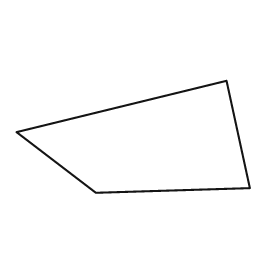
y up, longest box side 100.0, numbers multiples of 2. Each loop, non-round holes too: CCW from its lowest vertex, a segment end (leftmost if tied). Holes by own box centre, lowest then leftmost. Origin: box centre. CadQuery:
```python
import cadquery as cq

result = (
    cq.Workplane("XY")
    .moveTo(-16.0, -24.0)
    .lineTo(50.0, -22.0)
    .lineTo(40.0, 24.0)
    .lineTo(-50.0, 2.0)
    .close()
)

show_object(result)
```